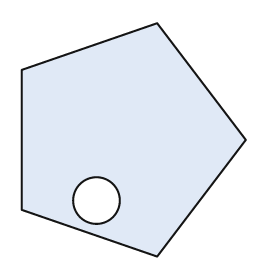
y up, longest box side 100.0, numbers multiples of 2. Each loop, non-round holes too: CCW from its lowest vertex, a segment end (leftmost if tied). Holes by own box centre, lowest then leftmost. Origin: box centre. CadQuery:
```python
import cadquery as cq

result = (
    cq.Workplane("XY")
    .moveTo(10.0, -50.0)
    .lineTo(48.0, 0.0)
    .lineTo(10.0, 50.0)
    .lineTo(-48.0, 30.0)
    .lineTo(-48.0, -30.0)
    .close()
    .moveTo(-16.0, -26.0)
    .circle(10.0)
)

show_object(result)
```